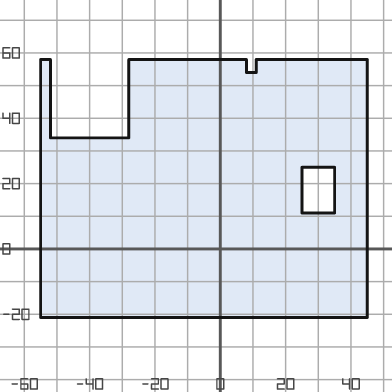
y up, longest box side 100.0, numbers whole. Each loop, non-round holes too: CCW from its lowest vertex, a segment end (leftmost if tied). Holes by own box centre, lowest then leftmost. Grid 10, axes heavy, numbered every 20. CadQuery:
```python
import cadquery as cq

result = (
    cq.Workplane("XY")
    .moveTo(-55.0, -21.0)
    .lineTo(45.0, -21.0)
    .lineTo(45.0, 58.0)
    .lineTo(11.0, 58.0)
    .lineTo(11.0, 54.0)
    .lineTo(8.0, 54.0)
    .lineTo(8.0, 58.0)
    .lineTo(-28.0, 58.0)
    .lineTo(-28.0, 34.0)
    .lineTo(-52.0, 34.0)
    .lineTo(-52.0, 58.0)
    .lineTo(-55.0, 58.0)
    .close()
    .moveTo(25.0, 11.0)
    .lineTo(35.0, 11.0)
    .lineTo(35.0, 25.0)
    .lineTo(25.0, 25.0)
    .close()
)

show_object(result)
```